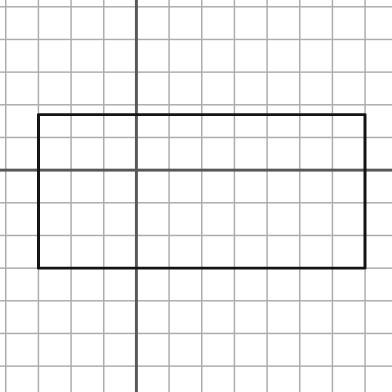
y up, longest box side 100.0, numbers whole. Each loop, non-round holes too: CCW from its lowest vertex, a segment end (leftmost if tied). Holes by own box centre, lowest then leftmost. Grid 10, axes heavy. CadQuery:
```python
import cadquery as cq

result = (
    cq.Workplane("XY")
    .moveTo(-30.0, -30.0)
    .lineTo(70.0, -30.0)
    .lineTo(70.0, 17.0)
    .lineTo(-30.0, 17.0)
    .close()
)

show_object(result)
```